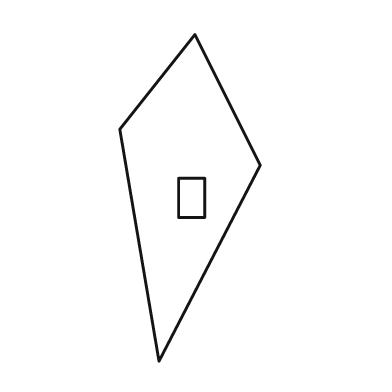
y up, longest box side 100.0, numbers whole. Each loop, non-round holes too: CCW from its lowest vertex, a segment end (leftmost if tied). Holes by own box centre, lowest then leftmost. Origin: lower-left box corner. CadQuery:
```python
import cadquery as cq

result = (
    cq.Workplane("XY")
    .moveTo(12.0, 0.0)
    .lineTo(43.0, 60.0)
    .lineTo(23.0, 100.0)
    .lineTo(0.0, 71.0)
    .close()
    .moveTo(18.0, 44.0)
    .lineTo(26.0, 44.0)
    .lineTo(26.0, 56.0)
    .lineTo(18.0, 56.0)
    .close()
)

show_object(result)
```